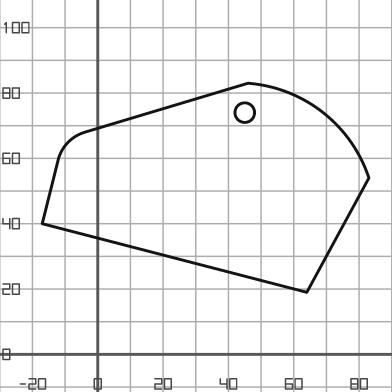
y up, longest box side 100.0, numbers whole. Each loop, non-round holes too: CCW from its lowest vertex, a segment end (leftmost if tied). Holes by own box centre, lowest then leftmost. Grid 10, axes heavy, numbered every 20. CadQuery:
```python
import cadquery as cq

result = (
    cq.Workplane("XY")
    .moveTo(64.0, 19.0)
    .lineTo(83.0, 54.0)
    .threePointArc((69.0, 74.0), (46.0, 83.0))
    .lineTo(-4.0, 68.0)
    .threePointArc((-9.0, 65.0), (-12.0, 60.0))
    .lineTo(-17.0, 40.0)
    .close()
    .moveTo(45.0, 74.0)
    .circle(3.0)
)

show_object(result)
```